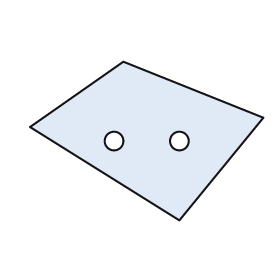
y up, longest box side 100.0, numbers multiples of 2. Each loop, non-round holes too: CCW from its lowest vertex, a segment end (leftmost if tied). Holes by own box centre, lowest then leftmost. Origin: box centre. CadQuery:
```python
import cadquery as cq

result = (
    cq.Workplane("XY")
    .moveTo(14.0, -34.0)
    .lineTo(50.0, 10.0)
    .lineTo(-10.0, 34.0)
    .lineTo(-50.0, 6.0)
    .close()
    .moveTo(-14.0, 0.0)
    .circle(4.0)
    .moveTo(14.0, 0.0)
    .circle(4.0)
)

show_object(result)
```